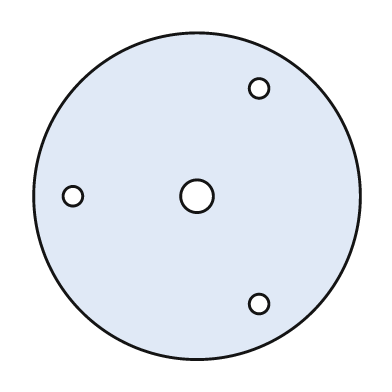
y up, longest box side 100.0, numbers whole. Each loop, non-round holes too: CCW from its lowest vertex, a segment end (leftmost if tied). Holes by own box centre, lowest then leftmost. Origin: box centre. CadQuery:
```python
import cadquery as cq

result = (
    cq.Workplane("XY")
    .moveTo(0.0, 0.0)
    .circle(50.0)
    .moveTo(19.0, -33.0)
    .circle(3.0)
    .moveTo(-38.0, 0.0)
    .circle(3.0)
    .moveTo(0.0, 0.0)
    .circle(5.0)
    .moveTo(19.0, 33.0)
    .circle(3.0)
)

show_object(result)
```